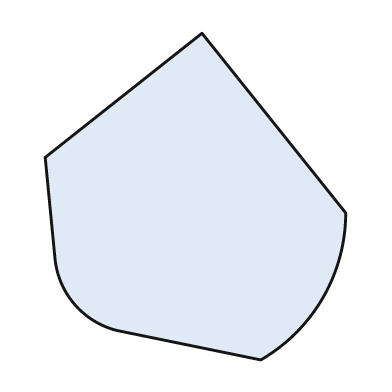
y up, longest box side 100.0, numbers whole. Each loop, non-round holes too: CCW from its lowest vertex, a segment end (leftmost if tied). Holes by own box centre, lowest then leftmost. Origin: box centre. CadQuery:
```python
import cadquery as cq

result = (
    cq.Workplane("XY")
    .moveTo(20.0, -50.0)
    .threePointArc((39.0, -31.0), (46.0, -5.0))
    .lineTo(2.0, 50.0)
    .lineTo(-46.0, 12.0)
    .lineTo(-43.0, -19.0)
    .threePointArc((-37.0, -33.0), (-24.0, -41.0))
    .close()
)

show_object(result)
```